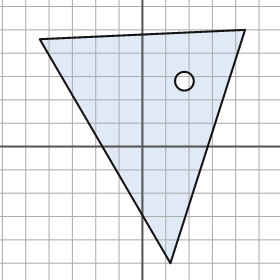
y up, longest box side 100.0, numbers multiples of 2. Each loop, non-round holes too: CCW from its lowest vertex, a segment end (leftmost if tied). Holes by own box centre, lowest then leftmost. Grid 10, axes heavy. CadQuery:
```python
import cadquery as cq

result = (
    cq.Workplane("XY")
    .moveTo(12.0, -50.0)
    .lineTo(44.0, 50.0)
    .lineTo(-44.0, 46.0)
    .close()
    .moveTo(18.0, 28.0)
    .circle(4.0)
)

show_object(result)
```